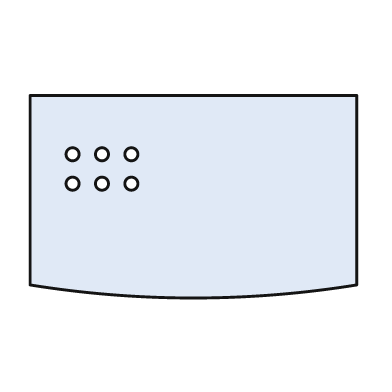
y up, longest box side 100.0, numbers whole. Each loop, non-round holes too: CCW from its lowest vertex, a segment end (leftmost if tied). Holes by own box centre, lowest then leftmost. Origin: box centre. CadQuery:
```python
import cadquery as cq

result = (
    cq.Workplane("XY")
    .moveTo(-50.0, -27.0)
    .threePointArc((0.0, -31.0), (50.0, -27.0))
    .lineTo(50.0, 31.0)
    .lineTo(-50.0, 31.0)
    .close()
    .moveTo(-37.0, 4.0)
    .circle(2.0)
    .moveTo(-28.0, 4.0)
    .circle(2.0)
    .moveTo(-19.0, 4.0)
    .circle(2.0)
    .moveTo(-37.0, 13.0)
    .circle(2.0)
    .moveTo(-28.0, 13.0)
    .circle(2.0)
    .moveTo(-19.0, 13.0)
    .circle(2.0)
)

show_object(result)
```